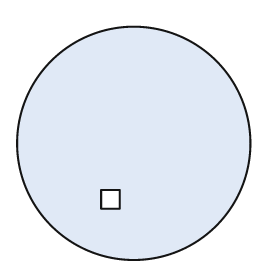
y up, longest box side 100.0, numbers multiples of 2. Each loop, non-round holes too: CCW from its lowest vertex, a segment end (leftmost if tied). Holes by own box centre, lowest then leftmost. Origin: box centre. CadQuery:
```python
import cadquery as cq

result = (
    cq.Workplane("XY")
    .moveTo(0.0, 0.0)
    .circle(50.0)
    .moveTo(-14.0, -28.0)
    .lineTo(-6.0, -28.0)
    .lineTo(-6.0, -20.0)
    .lineTo(-14.0, -20.0)
    .close()
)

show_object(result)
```